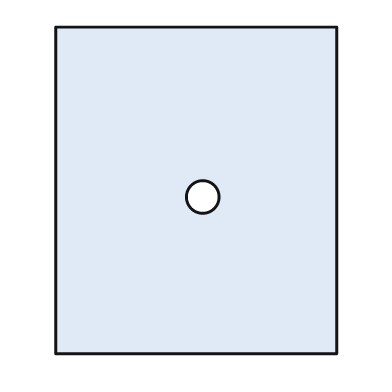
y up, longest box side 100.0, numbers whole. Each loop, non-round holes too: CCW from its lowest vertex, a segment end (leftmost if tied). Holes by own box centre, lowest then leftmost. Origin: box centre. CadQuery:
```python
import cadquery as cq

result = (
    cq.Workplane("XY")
    .moveTo(-43.0, -50.0)
    .lineTo(43.0, -50.0)
    .lineTo(43.0, 50.0)
    .lineTo(-43.0, 50.0)
    .close()
    .moveTo(2.0, -2.0)
    .circle(5.0)
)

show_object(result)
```